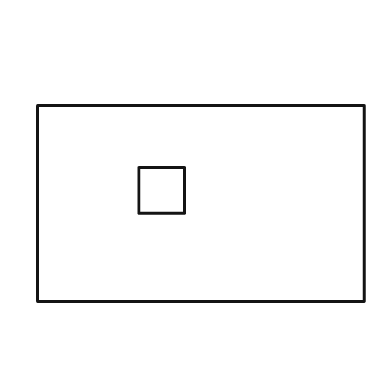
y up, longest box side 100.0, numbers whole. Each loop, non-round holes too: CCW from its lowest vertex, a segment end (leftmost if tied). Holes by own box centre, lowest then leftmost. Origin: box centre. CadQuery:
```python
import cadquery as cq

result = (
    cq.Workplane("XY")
    .moveTo(-50.0, -30.0)
    .lineTo(50.0, -30.0)
    .lineTo(50.0, 30.0)
    .lineTo(-50.0, 30.0)
    .close()
    .moveTo(-19.0, -3.0)
    .lineTo(-5.0, -3.0)
    .lineTo(-5.0, 11.0)
    .lineTo(-19.0, 11.0)
    .close()
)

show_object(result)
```